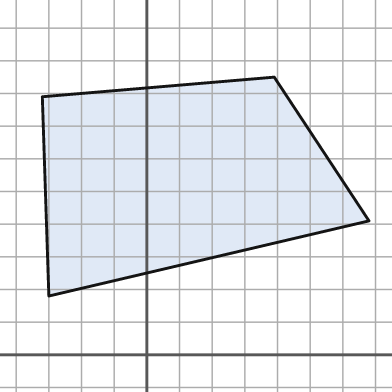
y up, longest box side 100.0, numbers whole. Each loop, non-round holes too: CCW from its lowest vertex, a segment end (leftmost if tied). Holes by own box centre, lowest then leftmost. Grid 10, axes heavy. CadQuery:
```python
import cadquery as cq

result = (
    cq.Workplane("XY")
    .moveTo(-30.0, 18.0)
    .lineTo(68.0, 41.0)
    .lineTo(39.0, 85.0)
    .lineTo(-32.0, 79.0)
    .close()
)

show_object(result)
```